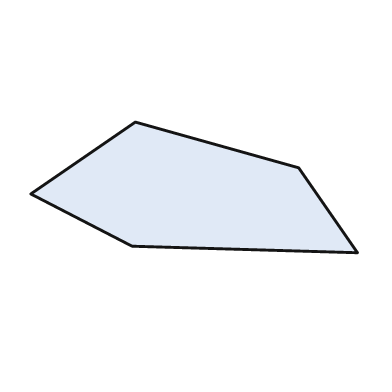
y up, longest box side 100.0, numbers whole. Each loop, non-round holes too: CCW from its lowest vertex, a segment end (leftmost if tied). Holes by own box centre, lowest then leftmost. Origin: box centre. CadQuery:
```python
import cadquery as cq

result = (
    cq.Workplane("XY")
    .moveTo(50.0, -20.0)
    .lineTo(32.0, 6.0)
    .lineTo(-18.0, 20.0)
    .lineTo(-50.0, -2.0)
    .lineTo(-19.0, -18.0)
    .close()
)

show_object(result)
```